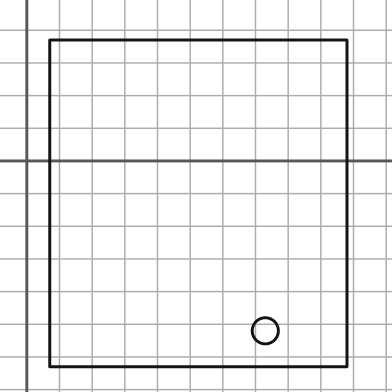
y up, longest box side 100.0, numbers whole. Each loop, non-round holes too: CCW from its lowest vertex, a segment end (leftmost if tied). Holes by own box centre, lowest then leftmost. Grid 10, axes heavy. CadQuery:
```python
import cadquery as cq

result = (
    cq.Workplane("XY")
    .moveTo(7.0, -63.0)
    .lineTo(98.0, -63.0)
    .lineTo(98.0, 37.0)
    .lineTo(7.0, 37.0)
    .close()
    .moveTo(73.0, -52.0)
    .circle(4.0)
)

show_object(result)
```